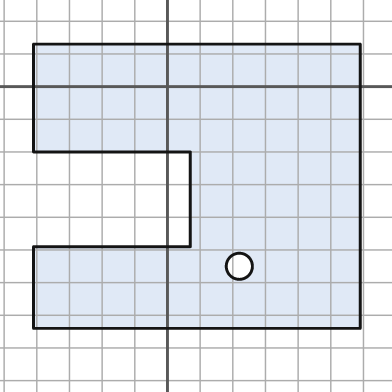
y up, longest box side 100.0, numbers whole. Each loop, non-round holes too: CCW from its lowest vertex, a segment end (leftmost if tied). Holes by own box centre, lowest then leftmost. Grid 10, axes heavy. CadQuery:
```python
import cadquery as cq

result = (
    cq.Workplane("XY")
    .moveTo(-41.0, -74.0)
    .lineTo(59.0, -74.0)
    .lineTo(59.0, 13.0)
    .lineTo(-41.0, 13.0)
    .lineTo(-41.0, -20.0)
    .lineTo(7.0, -20.0)
    .lineTo(7.0, -49.0)
    .lineTo(-41.0, -49.0)
    .close()
    .moveTo(22.0, -55.0)
    .circle(4.0)
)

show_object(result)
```